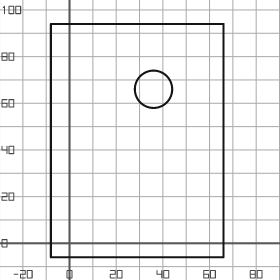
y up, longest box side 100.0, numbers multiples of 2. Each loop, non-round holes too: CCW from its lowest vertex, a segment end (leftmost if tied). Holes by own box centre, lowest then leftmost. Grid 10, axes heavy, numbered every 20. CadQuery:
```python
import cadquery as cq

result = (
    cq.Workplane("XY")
    .moveTo(-8.0, -6.0)
    .lineTo(66.0, -6.0)
    .lineTo(66.0, 94.0)
    .lineTo(-8.0, 94.0)
    .close()
    .moveTo(36.0, 66.0)
    .circle(8.0)
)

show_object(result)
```